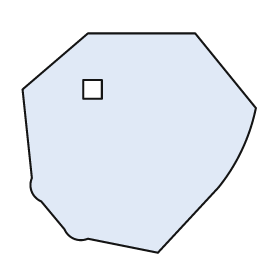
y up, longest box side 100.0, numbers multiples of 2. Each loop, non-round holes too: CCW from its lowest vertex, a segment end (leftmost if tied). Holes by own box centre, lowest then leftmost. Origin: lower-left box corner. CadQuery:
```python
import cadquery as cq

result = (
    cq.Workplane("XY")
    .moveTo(58.0, 0.0)
    .lineTo(84.0, 28.0)
    .threePointArc((94.0, 44.0), (100.0, 62.0))
    .lineTo(74.0, 94.0)
    .lineTo(28.0, 94.0)
    .lineTo(0.0, 70.0)
    .lineTo(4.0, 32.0)
    .threePointArc((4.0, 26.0), (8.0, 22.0))
    .lineTo(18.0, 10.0)
    .threePointArc((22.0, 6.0), (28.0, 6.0))
    .close()
    .moveTo(26.0, 66.0)
    .lineTo(34.0, 66.0)
    .lineTo(34.0, 74.0)
    .lineTo(26.0, 74.0)
    .close()
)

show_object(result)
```